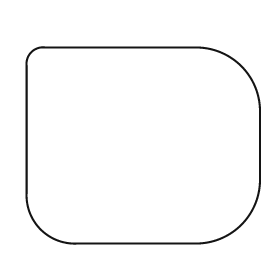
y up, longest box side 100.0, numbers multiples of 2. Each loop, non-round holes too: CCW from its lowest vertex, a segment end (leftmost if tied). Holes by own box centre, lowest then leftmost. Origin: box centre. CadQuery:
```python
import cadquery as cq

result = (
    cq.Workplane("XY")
    .moveTo(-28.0, -42.0)
    .lineTo(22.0, -42.0)
    .threePointArc((42.0, -34.0), (50.0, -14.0))
    .lineTo(50.0, 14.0)
    .threePointArc((42.0, 34.0), (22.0, 42.0))
    .lineTo(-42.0, 42.0)
    .threePointArc((-48.0, 40.0), (-50.0, 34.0))
    .lineTo(-50.0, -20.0)
    .threePointArc((-44.0, -36.0), (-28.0, -42.0))
    .close()
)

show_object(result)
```